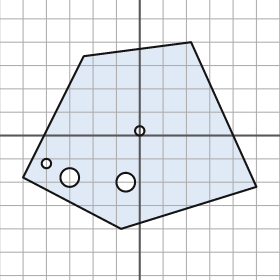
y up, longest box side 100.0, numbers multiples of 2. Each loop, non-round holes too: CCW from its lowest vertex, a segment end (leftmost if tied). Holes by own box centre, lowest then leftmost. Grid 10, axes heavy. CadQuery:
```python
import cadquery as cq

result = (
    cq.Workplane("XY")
    .moveTo(-8.0, -40.0)
    .lineTo(50.0, -22.0)
    .lineTo(22.0, 40.0)
    .lineTo(-24.0, 34.0)
    .lineTo(-50.0, -18.0)
    .close()
    .moveTo(-6.0, -20.0)
    .circle(4.0)
    .moveTo(-30.0, -18.0)
    .circle(4.0)
    .moveTo(-40.0, -12.0)
    .circle(2.0)
    .moveTo(0.0, 2.0)
    .circle(2.0)
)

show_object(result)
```